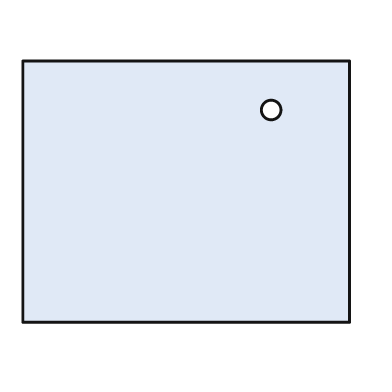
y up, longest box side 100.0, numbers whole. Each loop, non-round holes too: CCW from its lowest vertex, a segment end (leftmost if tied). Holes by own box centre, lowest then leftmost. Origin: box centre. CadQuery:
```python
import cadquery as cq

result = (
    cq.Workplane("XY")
    .moveTo(-50.0, -40.0)
    .lineTo(50.0, -40.0)
    .lineTo(50.0, 40.0)
    .lineTo(-50.0, 40.0)
    .close()
    .moveTo(26.0, 25.0)
    .circle(3.0)
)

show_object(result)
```